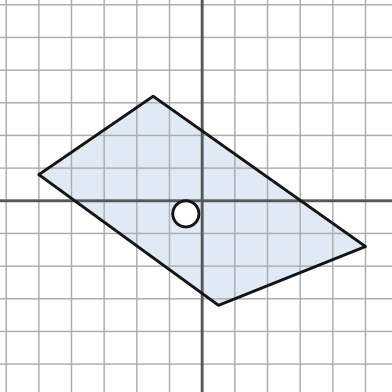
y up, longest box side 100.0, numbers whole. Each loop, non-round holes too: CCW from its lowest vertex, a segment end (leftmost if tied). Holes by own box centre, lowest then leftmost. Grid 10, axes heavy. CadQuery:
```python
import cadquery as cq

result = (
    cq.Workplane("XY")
    .moveTo(5.0, -32.0)
    .lineTo(50.0, -14.0)
    .lineTo(-15.0, 32.0)
    .lineTo(-50.0, 8.0)
    .close()
    .moveTo(-5.0, -4.0)
    .circle(4.0)
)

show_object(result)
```